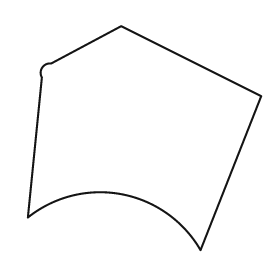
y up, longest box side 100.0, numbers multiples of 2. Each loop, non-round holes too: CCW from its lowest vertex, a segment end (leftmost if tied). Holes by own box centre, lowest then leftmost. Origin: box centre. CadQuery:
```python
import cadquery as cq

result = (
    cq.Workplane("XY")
    .moveTo(24.0, -48.0)
    .lineTo(50.0, 18.0)
    .lineTo(-10.0, 48.0)
    .lineTo(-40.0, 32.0)
    .threePointArc((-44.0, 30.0), (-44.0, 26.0))
    .lineTo(-50.0, -34.0)
    .threePointArc((-10.0, -24.0), (24.0, -48.0))
    .close()
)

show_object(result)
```